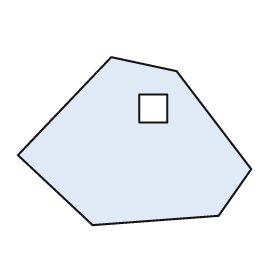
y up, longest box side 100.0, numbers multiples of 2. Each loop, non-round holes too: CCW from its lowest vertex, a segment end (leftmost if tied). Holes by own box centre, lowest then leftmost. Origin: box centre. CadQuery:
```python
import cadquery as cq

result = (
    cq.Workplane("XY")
    .moveTo(-18.0, -36.0)
    .lineTo(36.0, -32.0)
    .lineTo(50.0, -12.0)
    .lineTo(18.0, 30.0)
    .lineTo(-10.0, 36.0)
    .lineTo(-50.0, -6.0)
    .close()
    .moveTo(2.0, 8.0)
    .lineTo(14.0, 8.0)
    .lineTo(14.0, 20.0)
    .lineTo(2.0, 20.0)
    .close()
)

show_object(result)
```